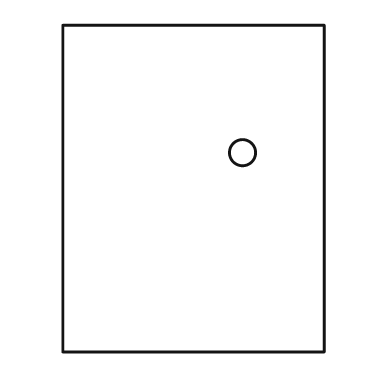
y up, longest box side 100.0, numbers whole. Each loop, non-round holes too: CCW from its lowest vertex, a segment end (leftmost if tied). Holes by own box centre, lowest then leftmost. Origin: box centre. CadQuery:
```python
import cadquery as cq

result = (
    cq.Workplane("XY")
    .moveTo(-40.0, -50.0)
    .lineTo(40.0, -50.0)
    .lineTo(40.0, 50.0)
    .lineTo(-40.0, 50.0)
    .close()
    .moveTo(15.0, 11.0)
    .circle(4.0)
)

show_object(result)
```